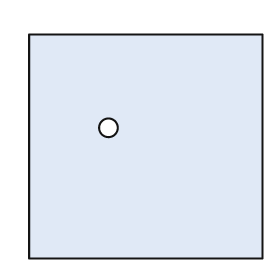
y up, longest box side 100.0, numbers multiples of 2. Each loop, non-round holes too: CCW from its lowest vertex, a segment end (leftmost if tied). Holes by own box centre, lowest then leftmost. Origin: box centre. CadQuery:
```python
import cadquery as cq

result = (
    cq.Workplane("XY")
    .moveTo(-50.0, -48.0)
    .lineTo(50.0, -48.0)
    .lineTo(50.0, 48.0)
    .lineTo(-50.0, 48.0)
    .close()
    .moveTo(-16.0, 8.0)
    .circle(4.0)
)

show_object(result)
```